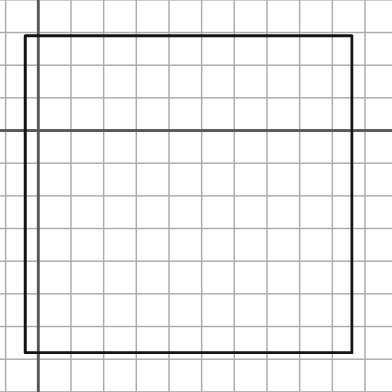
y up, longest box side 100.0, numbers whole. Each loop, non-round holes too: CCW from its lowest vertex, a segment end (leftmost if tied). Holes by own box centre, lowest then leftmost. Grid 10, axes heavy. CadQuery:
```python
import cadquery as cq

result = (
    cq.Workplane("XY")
    .moveTo(-4.0, -68.0)
    .lineTo(96.0, -68.0)
    .lineTo(96.0, 29.0)
    .lineTo(-4.0, 29.0)
    .close()
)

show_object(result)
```